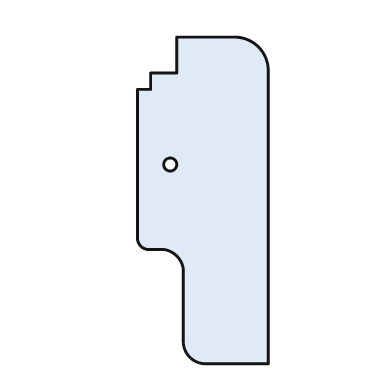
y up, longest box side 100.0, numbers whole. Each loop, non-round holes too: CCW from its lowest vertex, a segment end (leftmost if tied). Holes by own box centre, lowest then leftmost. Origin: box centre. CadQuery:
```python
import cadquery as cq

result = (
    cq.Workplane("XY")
    .moveTo(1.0, -50.0)
    .lineTo(20.0, -50.0)
    .lineTo(20.0, 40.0)
    .threePointArc((17.0, 47.0), (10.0, 50.0))
    .lineTo(-8.0, 50.0)
    .lineTo(-8.0, 39.0)
    .lineTo(-16.0, 39.0)
    .lineTo(-16.0, 34.0)
    .lineTo(-20.0, 34.0)
    .lineTo(-20.0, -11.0)
    .threePointArc((-19.0, -14.0), (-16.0, -15.0))
    .lineTo(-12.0, -15.0)
    .threePointArc((-8.0, -17.0), (-6.0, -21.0))
    .lineTo(-6.0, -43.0)
    .threePointArc((-4.0, -48.0), (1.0, -50.0))
    .close()
    .moveTo(-10.0, 11.0)
    .circle(2.0)
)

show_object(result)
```